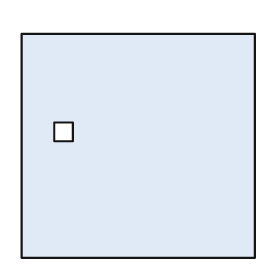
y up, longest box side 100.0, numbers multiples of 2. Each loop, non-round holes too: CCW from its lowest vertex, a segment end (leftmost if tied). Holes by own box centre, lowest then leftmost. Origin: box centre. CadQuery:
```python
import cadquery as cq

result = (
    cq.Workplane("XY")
    .moveTo(-50.0, -48.0)
    .lineTo(50.0, -48.0)
    .lineTo(50.0, 48.0)
    .lineTo(-50.0, 48.0)
    .close()
    .moveTo(-36.0, 2.0)
    .lineTo(-28.0, 2.0)
    .lineTo(-28.0, 10.0)
    .lineTo(-36.0, 10.0)
    .close()
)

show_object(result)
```